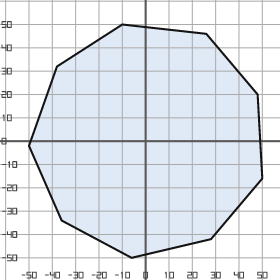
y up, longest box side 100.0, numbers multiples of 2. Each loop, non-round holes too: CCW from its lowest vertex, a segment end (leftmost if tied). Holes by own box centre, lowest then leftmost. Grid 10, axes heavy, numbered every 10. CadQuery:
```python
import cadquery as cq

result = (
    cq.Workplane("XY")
    .moveTo(-6.0, -50.0)
    .lineTo(28.0, -42.0)
    .lineTo(50.0, -16.0)
    .lineTo(48.0, 20.0)
    .lineTo(26.0, 46.0)
    .lineTo(-10.0, 50.0)
    .lineTo(-38.0, 32.0)
    .lineTo(-50.0, -2.0)
    .lineTo(-36.0, -34.0)
    .close()
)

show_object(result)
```